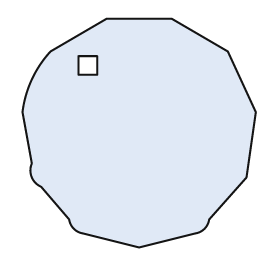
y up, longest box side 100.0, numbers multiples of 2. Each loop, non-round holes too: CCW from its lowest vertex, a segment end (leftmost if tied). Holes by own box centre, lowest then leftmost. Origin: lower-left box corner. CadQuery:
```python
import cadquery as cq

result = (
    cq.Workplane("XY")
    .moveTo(50.0, 0.0)
    .lineTo(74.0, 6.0)
    .threePointArc((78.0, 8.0), (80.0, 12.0))
    .lineTo(96.0, 30.0)
    .lineTo(100.0, 58.0)
    .lineTo(88.0, 84.0)
    .lineTo(64.0, 98.0)
    .lineTo(36.0, 98.0)
    .lineTo(12.0, 84.0)
    .threePointArc((4.0, 72.0), (0.0, 58.0))
    .lineTo(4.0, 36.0)
    .threePointArc((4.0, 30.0), (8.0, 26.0))
    .lineTo(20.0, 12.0)
    .threePointArc((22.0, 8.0), (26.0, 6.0))
    .close()
    .moveTo(24.0, 74.0)
    .lineTo(32.0, 74.0)
    .lineTo(32.0, 82.0)
    .lineTo(24.0, 82.0)
    .close()
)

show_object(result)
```